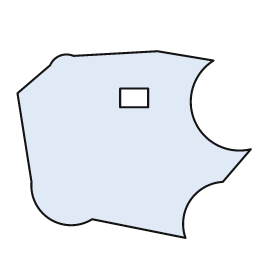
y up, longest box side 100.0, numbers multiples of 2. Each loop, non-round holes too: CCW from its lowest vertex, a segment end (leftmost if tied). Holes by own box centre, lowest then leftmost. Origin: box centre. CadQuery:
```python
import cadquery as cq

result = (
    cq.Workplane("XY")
    .moveTo(22.0, -40.0)
    .threePointArc((24.0, -24.0), (38.0, -16.0))
    .lineTo(50.0, -2.0)
    .threePointArc((26.0, 10.0), (34.0, 36.0))
    .lineTo(10.0, 40.0)
    .lineTo(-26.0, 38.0)
    .threePointArc((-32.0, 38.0), (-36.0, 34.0))
    .lineTo(-50.0, 22.0)
    .lineTo(-44.0, -16.0)
    .threePointArc((-36.0, -32.0), (-18.0, -32.0))
    .close()
    .moveTo(-6.0, 16.0)
    .lineTo(6.0, 16.0)
    .lineTo(6.0, 24.0)
    .lineTo(-6.0, 24.0)
    .close()
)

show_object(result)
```